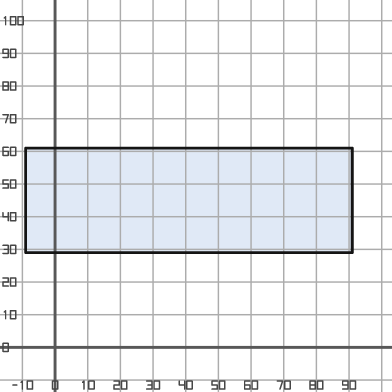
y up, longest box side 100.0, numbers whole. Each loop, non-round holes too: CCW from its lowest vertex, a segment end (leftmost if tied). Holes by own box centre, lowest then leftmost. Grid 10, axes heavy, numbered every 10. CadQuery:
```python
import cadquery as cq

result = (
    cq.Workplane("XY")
    .moveTo(-9.0, 29.0)
    .lineTo(91.0, 29.0)
    .lineTo(91.0, 61.0)
    .lineTo(-9.0, 61.0)
    .close()
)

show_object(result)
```